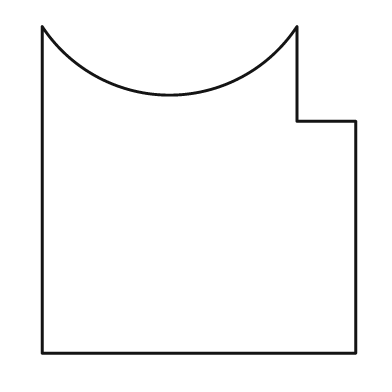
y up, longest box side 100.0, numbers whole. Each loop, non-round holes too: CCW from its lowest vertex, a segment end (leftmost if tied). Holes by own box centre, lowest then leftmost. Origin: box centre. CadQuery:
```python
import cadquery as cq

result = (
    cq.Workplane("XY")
    .moveTo(-48.0, -50.0)
    .lineTo(48.0, -50.0)
    .lineTo(48.0, 21.0)
    .lineTo(30.0, 21.0)
    .lineTo(30.0, 50.0)
    .threePointArc((-9.0, 29.0), (-48.0, 50.0))
    .close()
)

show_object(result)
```